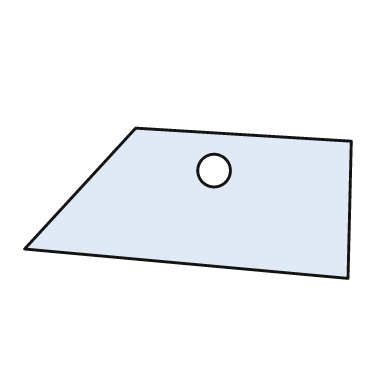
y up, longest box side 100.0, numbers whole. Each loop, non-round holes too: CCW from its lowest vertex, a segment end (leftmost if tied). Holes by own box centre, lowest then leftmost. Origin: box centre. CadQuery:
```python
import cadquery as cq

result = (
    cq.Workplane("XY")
    .moveTo(49.0, -23.0)
    .lineTo(50.0, 19.0)
    .lineTo(-16.0, 23.0)
    .lineTo(-50.0, -14.0)
    .close()
    .moveTo(8.0, 10.0)
    .circle(5.0)
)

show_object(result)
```